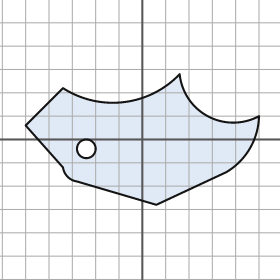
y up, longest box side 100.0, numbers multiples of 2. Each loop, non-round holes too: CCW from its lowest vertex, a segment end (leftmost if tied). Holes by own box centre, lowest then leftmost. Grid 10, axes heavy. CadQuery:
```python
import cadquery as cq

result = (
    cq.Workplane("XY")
    .moveTo(6.0, -28.0)
    .lineTo(36.0, -14.0)
    .threePointArc((46.0, -4.0), (50.0, 10.0))
    .threePointArc((28.0, 10.0), (16.0, 28.0))
    .threePointArc((-8.0, 16.0), (-34.0, 22.0))
    .lineTo(-50.0, 6.0)
    .lineTo(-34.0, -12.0)
    .threePointArc((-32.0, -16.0), (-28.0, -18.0))
    .close()
    .moveTo(-24.0, -4.0)
    .circle(4.0)
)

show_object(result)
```